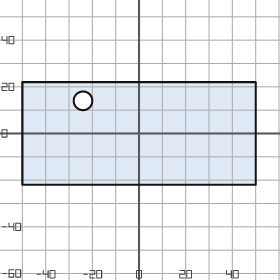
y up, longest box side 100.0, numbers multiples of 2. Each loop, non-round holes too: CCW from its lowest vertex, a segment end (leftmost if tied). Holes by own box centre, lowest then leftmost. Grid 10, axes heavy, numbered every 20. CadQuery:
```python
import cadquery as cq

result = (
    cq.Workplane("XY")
    .moveTo(-50.0, -22.0)
    .lineTo(50.0, -22.0)
    .lineTo(50.0, 22.0)
    .lineTo(-50.0, 22.0)
    .close()
    .moveTo(-24.0, 14.0)
    .circle(4.0)
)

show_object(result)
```